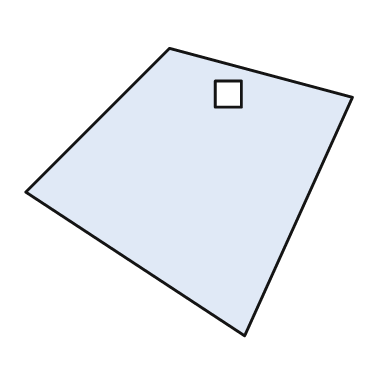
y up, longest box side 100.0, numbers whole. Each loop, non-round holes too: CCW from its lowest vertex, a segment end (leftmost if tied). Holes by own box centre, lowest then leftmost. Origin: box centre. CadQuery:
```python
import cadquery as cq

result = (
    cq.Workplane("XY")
    .moveTo(17.0, -44.0)
    .lineTo(50.0, 29.0)
    .lineTo(-6.0, 44.0)
    .lineTo(-50.0, 0.0)
    .close()
    .moveTo(8.0, 26.0)
    .lineTo(16.0, 26.0)
    .lineTo(16.0, 34.0)
    .lineTo(8.0, 34.0)
    .close()
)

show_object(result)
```